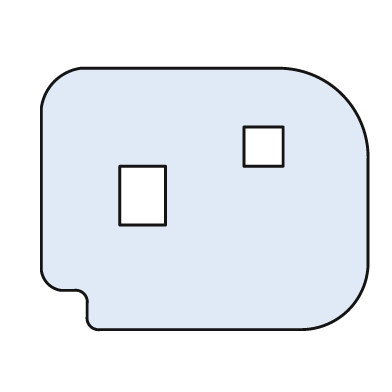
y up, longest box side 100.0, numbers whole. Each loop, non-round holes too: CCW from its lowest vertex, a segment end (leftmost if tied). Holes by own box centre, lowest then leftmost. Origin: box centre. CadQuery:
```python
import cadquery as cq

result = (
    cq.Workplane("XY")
    .moveTo(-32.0, -40.0)
    .lineTo(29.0, -40.0)
    .threePointArc((44.0, -34.0), (50.0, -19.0))
    .lineTo(50.0, 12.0)
    .threePointArc((42.0, 32.0), (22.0, 40.0))
    .lineTo(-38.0, 40.0)
    .threePointArc((-46.0, 36.0), (-50.0, 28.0))
    .lineTo(-50.0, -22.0)
    .threePointArc((-48.0, -26.0), (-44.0, -28.0))
    .lineTo(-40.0, -28.0)
    .threePointArc((-37.0, -29.0), (-36.0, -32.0))
    .lineTo(-36.0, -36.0)
    .threePointArc((-35.0, -39.0), (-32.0, -40.0))
    .close()
    .moveTo(-26.0, -8.0)
    .lineTo(-12.0, -8.0)
    .lineTo(-12.0, 10.0)
    .lineTo(-26.0, 10.0)
    .close()
    .moveTo(12.0, 10.0)
    .lineTo(24.0, 10.0)
    .lineTo(24.0, 22.0)
    .lineTo(12.0, 22.0)
    .close()
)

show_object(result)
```